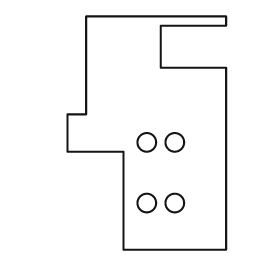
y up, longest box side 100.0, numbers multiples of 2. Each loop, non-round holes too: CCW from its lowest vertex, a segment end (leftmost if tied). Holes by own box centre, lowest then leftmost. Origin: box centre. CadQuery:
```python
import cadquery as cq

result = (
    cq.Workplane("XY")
    .moveTo(-10.0, -50.0)
    .lineTo(34.0, -50.0)
    .lineTo(34.0, 28.0)
    .lineTo(6.0, 28.0)
    .lineTo(6.0, 46.0)
    .lineTo(34.0, 46.0)
    .lineTo(34.0, 50.0)
    .lineTo(-26.0, 50.0)
    .lineTo(-26.0, 8.0)
    .lineTo(-34.0, 8.0)
    .lineTo(-34.0, -8.0)
    .lineTo(-10.0, -8.0)
    .close()
    .moveTo(0.0, -30.0)
    .circle(4.0)
    .moveTo(12.0, -30.0)
    .circle(4.0)
    .moveTo(0.0, -4.0)
    .circle(4.0)
    .moveTo(12.0, -4.0)
    .circle(4.0)
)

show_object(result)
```